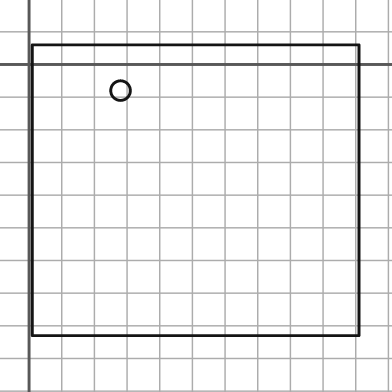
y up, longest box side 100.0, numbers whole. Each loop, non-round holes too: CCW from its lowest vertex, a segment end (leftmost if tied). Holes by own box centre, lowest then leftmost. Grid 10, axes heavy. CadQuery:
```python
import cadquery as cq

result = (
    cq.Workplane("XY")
    .moveTo(1.0, -83.0)
    .lineTo(101.0, -83.0)
    .lineTo(101.0, 6.0)
    .lineTo(1.0, 6.0)
    .close()
    .moveTo(28.0, -8.0)
    .circle(3.0)
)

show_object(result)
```